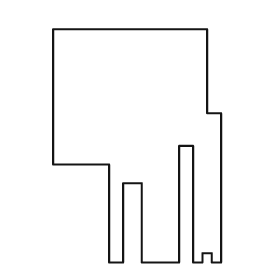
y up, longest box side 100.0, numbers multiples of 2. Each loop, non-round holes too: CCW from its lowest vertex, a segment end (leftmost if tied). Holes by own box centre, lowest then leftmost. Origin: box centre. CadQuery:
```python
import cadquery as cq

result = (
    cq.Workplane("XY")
    .moveTo(-12.0, -50.0)
    .lineTo(-6.0, -50.0)
    .lineTo(-6.0, -16.0)
    .lineTo(2.0, -16.0)
    .lineTo(2.0, -50.0)
    .lineTo(18.0, -50.0)
    .lineTo(18.0, 0.0)
    .lineTo(24.0, 0.0)
    .lineTo(24.0, -50.0)
    .lineTo(28.0, -50.0)
    .lineTo(28.0, -46.0)
    .lineTo(32.0, -46.0)
    .lineTo(32.0, -50.0)
    .lineTo(36.0, -50.0)
    .lineTo(36.0, 14.0)
    .lineTo(30.0, 14.0)
    .lineTo(30.0, 50.0)
    .lineTo(-36.0, 50.0)
    .lineTo(-36.0, -8.0)
    .lineTo(-12.0, -8.0)
    .close()
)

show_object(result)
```